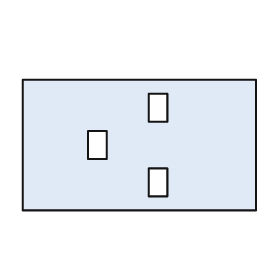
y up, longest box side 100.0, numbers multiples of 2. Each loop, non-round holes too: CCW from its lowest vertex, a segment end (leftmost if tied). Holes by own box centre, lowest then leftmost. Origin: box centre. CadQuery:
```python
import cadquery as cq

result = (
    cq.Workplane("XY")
    .moveTo(-50.0, -28.0)
    .lineTo(50.0, -28.0)
    .lineTo(50.0, 28.0)
    .lineTo(-50.0, 28.0)
    .close()
    .moveTo(4.0, -22.0)
    .lineTo(12.0, -22.0)
    .lineTo(12.0, -10.0)
    .lineTo(4.0, -10.0)
    .close()
    .moveTo(-22.0, -6.0)
    .lineTo(-14.0, -6.0)
    .lineTo(-14.0, 6.0)
    .lineTo(-22.0, 6.0)
    .close()
    .moveTo(4.0, 10.0)
    .lineTo(12.0, 10.0)
    .lineTo(12.0, 22.0)
    .lineTo(4.0, 22.0)
    .close()
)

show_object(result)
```